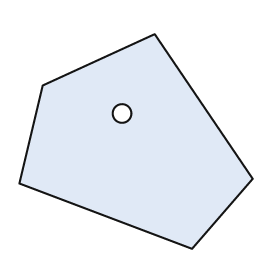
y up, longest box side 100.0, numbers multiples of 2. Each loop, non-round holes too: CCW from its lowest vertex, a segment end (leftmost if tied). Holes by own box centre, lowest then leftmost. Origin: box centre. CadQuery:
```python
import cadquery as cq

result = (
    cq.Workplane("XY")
    .moveTo(24.0, -46.0)
    .lineTo(50.0, -16.0)
    .lineTo(8.0, 46.0)
    .lineTo(-40.0, 24.0)
    .lineTo(-50.0, -18.0)
    .close()
    .moveTo(-6.0, 12.0)
    .circle(4.0)
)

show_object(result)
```